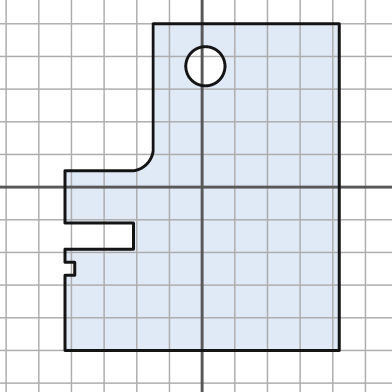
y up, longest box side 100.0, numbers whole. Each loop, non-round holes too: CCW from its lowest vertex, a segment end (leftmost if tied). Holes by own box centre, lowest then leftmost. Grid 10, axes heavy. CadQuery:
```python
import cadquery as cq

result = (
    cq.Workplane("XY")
    .moveTo(-42.0, -50.0)
    .lineTo(42.0, -50.0)
    .lineTo(42.0, 50.0)
    .lineTo(-15.0, 50.0)
    .lineTo(-15.0, 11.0)
    .threePointArc((-17.0, 7.0), (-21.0, 5.0))
    .lineTo(-42.0, 5.0)
    .lineTo(-42.0, -11.0)
    .lineTo(-21.0, -11.0)
    .lineTo(-21.0, -19.0)
    .lineTo(-42.0, -19.0)
    .lineTo(-42.0, -23.0)
    .lineTo(-39.0, -23.0)
    .lineTo(-39.0, -27.0)
    .lineTo(-42.0, -27.0)
    .close()
    .moveTo(1.0, 37.0)
    .circle(6.0)
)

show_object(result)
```